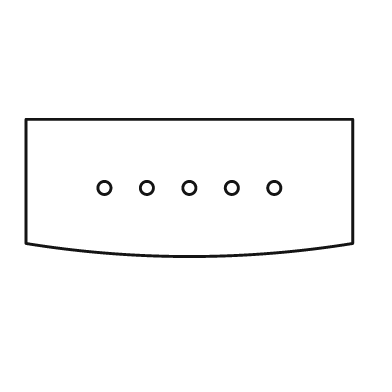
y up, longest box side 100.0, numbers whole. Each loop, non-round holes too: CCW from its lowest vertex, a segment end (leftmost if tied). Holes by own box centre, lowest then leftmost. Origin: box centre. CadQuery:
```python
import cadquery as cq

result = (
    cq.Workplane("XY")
    .moveTo(-50.0, -17.0)
    .threePointArc((0.0, -21.0), (50.0, -17.0))
    .lineTo(50.0, 21.0)
    .lineTo(-50.0, 21.0)
    .close()
    .moveTo(-26.0, 0.0)
    .circle(2.0)
    .moveTo(-13.0, 0.0)
    .circle(2.0)
    .moveTo(0.0, 0.0)
    .circle(2.0)
    .moveTo(13.0, 0.0)
    .circle(2.0)
    .moveTo(26.0, 0.0)
    .circle(2.0)
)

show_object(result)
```